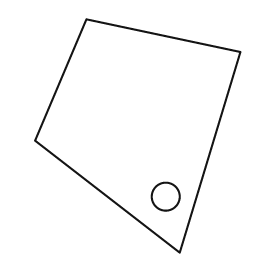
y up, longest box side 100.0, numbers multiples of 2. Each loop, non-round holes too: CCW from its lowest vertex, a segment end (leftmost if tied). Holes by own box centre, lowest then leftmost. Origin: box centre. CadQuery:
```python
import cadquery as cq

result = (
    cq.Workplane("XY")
    .moveTo(18.0, -50.0)
    .lineTo(44.0, 36.0)
    .lineTo(-22.0, 50.0)
    .lineTo(-44.0, -2.0)
    .close()
    .moveTo(12.0, -26.0)
    .circle(6.0)
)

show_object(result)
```